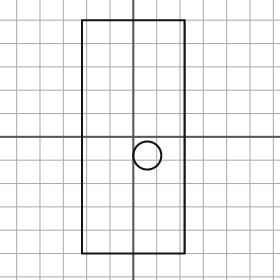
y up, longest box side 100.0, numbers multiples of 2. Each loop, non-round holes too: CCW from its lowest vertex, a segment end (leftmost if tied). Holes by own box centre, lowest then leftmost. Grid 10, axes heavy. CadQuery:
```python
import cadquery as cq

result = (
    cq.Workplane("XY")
    .moveTo(-22.0, -50.0)
    .lineTo(22.0, -50.0)
    .lineTo(22.0, 50.0)
    .lineTo(-22.0, 50.0)
    .close()
    .moveTo(6.0, -8.0)
    .circle(6.0)
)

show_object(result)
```